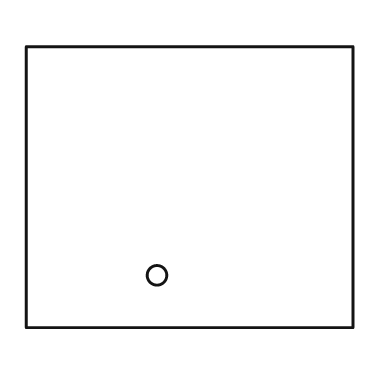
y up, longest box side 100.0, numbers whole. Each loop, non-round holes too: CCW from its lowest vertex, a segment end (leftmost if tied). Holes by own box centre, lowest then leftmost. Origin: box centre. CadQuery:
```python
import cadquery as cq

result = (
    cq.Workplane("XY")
    .moveTo(-50.0, -43.0)
    .lineTo(50.0, -43.0)
    .lineTo(50.0, 43.0)
    .lineTo(-50.0, 43.0)
    .close()
    .moveTo(-10.0, -27.0)
    .circle(3.0)
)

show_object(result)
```